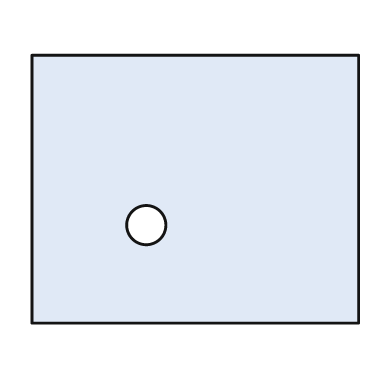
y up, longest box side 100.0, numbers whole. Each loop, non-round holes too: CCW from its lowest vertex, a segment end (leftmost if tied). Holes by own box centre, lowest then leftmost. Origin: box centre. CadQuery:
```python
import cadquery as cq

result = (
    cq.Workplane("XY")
    .moveTo(-50.0, -41.0)
    .lineTo(50.0, -41.0)
    .lineTo(50.0, 41.0)
    .lineTo(-50.0, 41.0)
    .close()
    .moveTo(-15.0, -11.0)
    .circle(6.0)
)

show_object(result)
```